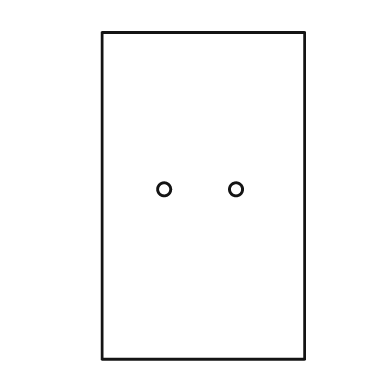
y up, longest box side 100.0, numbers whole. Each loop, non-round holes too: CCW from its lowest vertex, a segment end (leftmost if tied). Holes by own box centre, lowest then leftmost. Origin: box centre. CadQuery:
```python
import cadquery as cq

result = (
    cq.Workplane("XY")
    .moveTo(-31.0, -50.0)
    .lineTo(31.0, -50.0)
    .lineTo(31.0, 50.0)
    .lineTo(-31.0, 50.0)
    .close()
    .moveTo(-12.0, 2.0)
    .circle(2.0)
    .moveTo(10.0, 2.0)
    .circle(2.0)
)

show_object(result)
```